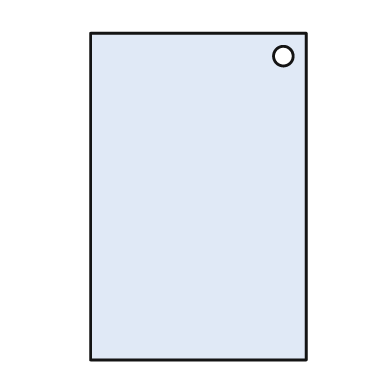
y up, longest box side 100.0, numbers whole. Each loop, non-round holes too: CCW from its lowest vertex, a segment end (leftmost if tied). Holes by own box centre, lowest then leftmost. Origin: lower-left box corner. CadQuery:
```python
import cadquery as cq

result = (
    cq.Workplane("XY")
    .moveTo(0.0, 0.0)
    .lineTo(66.0, 0.0)
    .lineTo(66.0, 100.0)
    .lineTo(0.0, 100.0)
    .close()
    .moveTo(59.0, 93.0)
    .circle(3.0)
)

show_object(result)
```